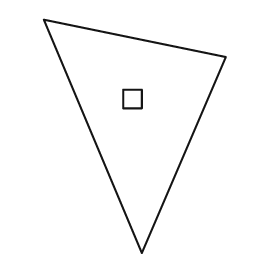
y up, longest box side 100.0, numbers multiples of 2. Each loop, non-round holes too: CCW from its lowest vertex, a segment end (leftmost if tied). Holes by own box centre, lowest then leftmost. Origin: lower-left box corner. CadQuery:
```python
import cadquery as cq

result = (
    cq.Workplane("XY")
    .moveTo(42.0, 0.0)
    .lineTo(78.0, 84.0)
    .lineTo(0.0, 100.0)
    .close()
    .moveTo(34.0, 62.0)
    .lineTo(42.0, 62.0)
    .lineTo(42.0, 70.0)
    .lineTo(34.0, 70.0)
    .close()
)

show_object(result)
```